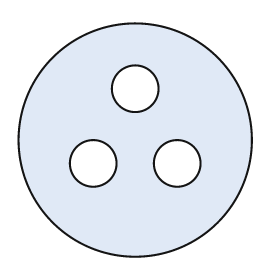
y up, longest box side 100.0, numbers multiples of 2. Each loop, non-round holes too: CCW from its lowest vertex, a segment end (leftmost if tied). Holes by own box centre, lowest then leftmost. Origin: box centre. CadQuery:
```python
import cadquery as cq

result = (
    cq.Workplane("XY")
    .moveTo(0.0, 0.0)
    .circle(50.0)
    .moveTo(-18.0, -10.0)
    .circle(10.0)
    .moveTo(18.0, -10.0)
    .circle(10.0)
    .moveTo(0.0, 22.0)
    .circle(10.0)
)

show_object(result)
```